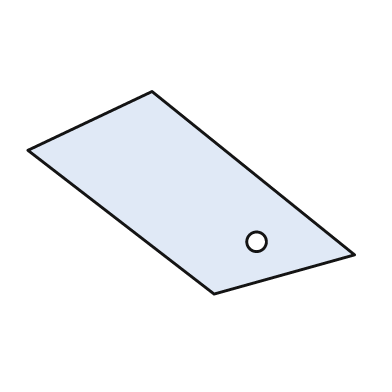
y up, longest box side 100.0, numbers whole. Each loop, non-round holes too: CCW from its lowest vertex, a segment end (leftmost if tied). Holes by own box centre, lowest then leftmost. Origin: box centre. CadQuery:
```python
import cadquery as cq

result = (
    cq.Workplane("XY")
    .moveTo(7.0, -31.0)
    .lineTo(50.0, -19.0)
    .lineTo(-12.0, 31.0)
    .lineTo(-50.0, 13.0)
    .close()
    .moveTo(20.0, -15.0)
    .circle(3.0)
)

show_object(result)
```